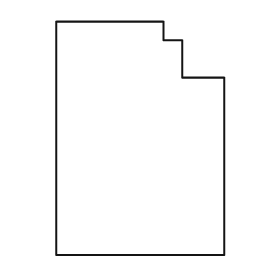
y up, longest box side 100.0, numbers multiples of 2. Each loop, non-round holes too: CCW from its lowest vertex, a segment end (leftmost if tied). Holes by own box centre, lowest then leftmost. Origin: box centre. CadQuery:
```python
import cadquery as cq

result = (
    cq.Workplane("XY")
    .moveTo(-36.0, -50.0)
    .lineTo(36.0, -50.0)
    .lineTo(36.0, 26.0)
    .lineTo(18.0, 26.0)
    .lineTo(18.0, 42.0)
    .lineTo(10.0, 42.0)
    .lineTo(10.0, 50.0)
    .lineTo(-36.0, 50.0)
    .close()
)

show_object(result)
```